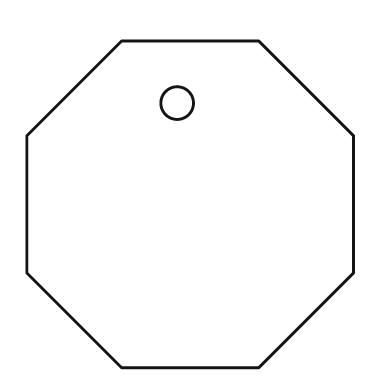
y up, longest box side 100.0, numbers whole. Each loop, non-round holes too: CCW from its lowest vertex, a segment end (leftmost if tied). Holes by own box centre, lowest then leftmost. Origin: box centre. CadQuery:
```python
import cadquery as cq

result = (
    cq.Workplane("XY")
    .moveTo(-21.0, -50.0)
    .lineTo(21.0, -50.0)
    .lineTo(50.0, -21.0)
    .lineTo(50.0, 21.0)
    .lineTo(21.0, 50.0)
    .lineTo(-21.0, 50.0)
    .lineTo(-50.0, 21.0)
    .lineTo(-50.0, -21.0)
    .close()
    .moveTo(-4.0, 31.0)
    .circle(5.0)
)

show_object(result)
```